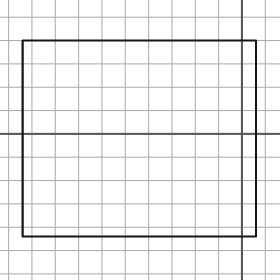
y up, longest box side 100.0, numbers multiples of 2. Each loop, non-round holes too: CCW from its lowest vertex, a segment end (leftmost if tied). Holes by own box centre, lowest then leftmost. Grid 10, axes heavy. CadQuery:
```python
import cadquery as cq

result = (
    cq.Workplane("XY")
    .moveTo(-94.0, -44.0)
    .lineTo(6.0, -44.0)
    .lineTo(6.0, 40.0)
    .lineTo(-94.0, 40.0)
    .close()
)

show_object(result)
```